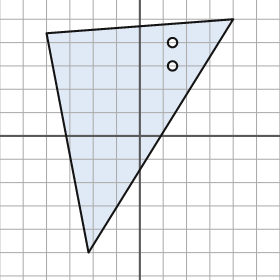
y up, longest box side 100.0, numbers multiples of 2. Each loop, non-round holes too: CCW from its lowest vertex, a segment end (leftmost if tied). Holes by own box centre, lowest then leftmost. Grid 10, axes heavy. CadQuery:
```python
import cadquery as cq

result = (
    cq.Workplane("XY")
    .moveTo(-22.0, -50.0)
    .lineTo(40.0, 50.0)
    .lineTo(-40.0, 44.0)
    .close()
    .moveTo(14.0, 30.0)
    .circle(2.0)
    .moveTo(14.0, 40.0)
    .circle(2.0)
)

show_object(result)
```